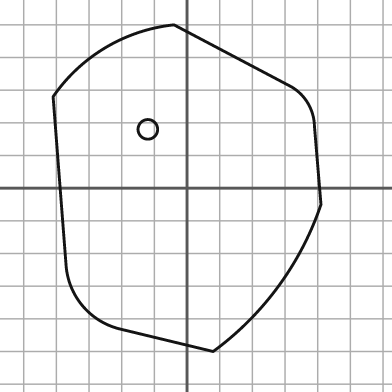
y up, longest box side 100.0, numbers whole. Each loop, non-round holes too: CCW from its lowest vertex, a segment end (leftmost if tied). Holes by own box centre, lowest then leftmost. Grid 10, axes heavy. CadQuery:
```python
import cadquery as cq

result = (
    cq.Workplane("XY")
    .moveTo(8.0, -50.0)
    .threePointArc((28.0, -30.0), (41.0, -5.0))
    .lineTo(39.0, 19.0)
    .threePointArc((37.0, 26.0), (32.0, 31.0))
    .lineTo(-4.0, 50.0)
    .threePointArc((-25.0, 43.0), (-41.0, 28.0))
    .lineTo(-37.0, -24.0)
    .threePointArc((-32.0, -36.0), (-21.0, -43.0))
    .close()
    .moveTo(-12.0, 18.0)
    .circle(3.0)
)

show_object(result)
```